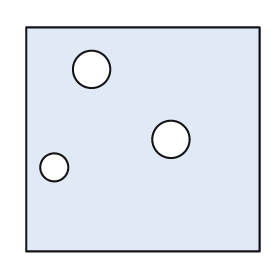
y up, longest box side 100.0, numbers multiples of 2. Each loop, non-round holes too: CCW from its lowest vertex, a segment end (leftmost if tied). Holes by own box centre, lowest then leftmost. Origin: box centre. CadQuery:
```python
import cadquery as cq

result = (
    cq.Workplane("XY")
    .moveTo(-50.0, -48.0)
    .lineTo(50.0, -48.0)
    .lineTo(50.0, 48.0)
    .lineTo(-50.0, 48.0)
    .close()
    .moveTo(-38.0, -12.0)
    .circle(6.0)
    .moveTo(12.0, 0.0)
    .circle(8.0)
    .moveTo(-22.0, 30.0)
    .circle(8.0)
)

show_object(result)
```